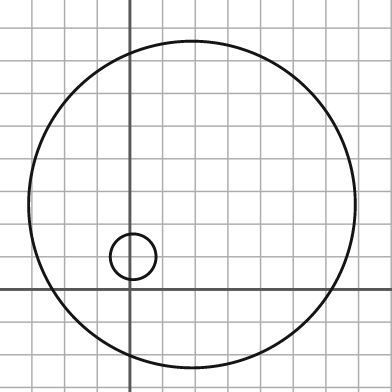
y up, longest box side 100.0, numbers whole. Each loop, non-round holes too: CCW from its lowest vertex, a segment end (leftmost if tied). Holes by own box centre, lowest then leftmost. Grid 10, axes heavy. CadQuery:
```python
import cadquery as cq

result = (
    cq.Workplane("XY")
    .moveTo(19.0, 26.0)
    .circle(50.0)
    .moveTo(1.0, 10.0)
    .circle(7.0)
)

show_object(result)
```